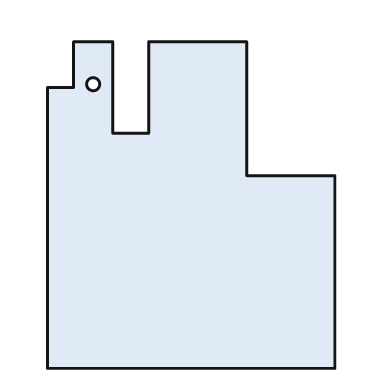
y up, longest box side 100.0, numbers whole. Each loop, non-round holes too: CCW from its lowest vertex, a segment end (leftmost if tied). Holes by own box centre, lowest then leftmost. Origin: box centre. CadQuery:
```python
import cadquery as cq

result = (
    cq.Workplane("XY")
    .moveTo(-44.0, -50.0)
    .lineTo(44.0, -50.0)
    .lineTo(44.0, 9.0)
    .lineTo(17.0, 9.0)
    .lineTo(17.0, 50.0)
    .lineTo(-13.0, 50.0)
    .lineTo(-13.0, 22.0)
    .lineTo(-24.0, 22.0)
    .lineTo(-24.0, 50.0)
    .lineTo(-36.0, 50.0)
    .lineTo(-36.0, 36.0)
    .lineTo(-44.0, 36.0)
    .close()
    .moveTo(-30.0, 37.0)
    .circle(2.0)
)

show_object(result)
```